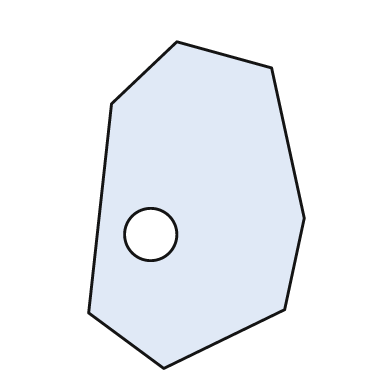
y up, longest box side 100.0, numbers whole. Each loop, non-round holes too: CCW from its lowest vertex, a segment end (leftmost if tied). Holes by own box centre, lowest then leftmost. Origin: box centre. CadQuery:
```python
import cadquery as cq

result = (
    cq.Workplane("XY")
    .moveTo(-10.0, -50.0)
    .lineTo(27.0, -32.0)
    .lineTo(33.0, -4.0)
    .lineTo(23.0, 42.0)
    .lineTo(-6.0, 50.0)
    .lineTo(-26.0, 31.0)
    .lineTo(-33.0, -33.0)
    .close()
    .moveTo(-14.0, -9.0)
    .circle(8.0)
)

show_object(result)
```